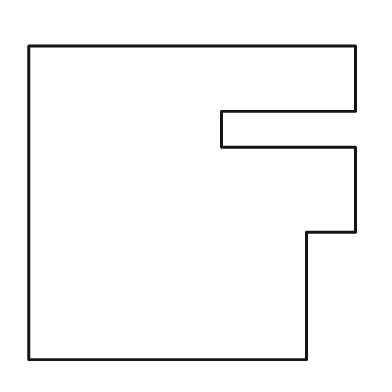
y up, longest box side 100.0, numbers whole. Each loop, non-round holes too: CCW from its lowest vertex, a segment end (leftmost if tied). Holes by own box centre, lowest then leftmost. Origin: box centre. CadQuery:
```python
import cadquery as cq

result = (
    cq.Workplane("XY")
    .moveTo(-50.0, -48.0)
    .lineTo(35.0, -48.0)
    .lineTo(35.0, -9.0)
    .lineTo(50.0, -9.0)
    .lineTo(50.0, 17.0)
    .lineTo(9.0, 17.0)
    .lineTo(9.0, 28.0)
    .lineTo(50.0, 28.0)
    .lineTo(50.0, 48.0)
    .lineTo(-50.0, 48.0)
    .close()
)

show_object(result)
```